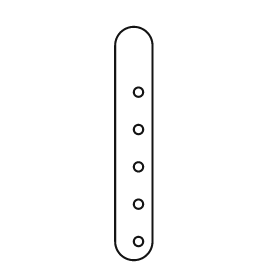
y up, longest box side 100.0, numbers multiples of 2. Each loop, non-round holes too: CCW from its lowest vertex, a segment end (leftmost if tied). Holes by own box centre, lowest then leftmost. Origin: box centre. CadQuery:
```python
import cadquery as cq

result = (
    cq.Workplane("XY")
    .moveTo(-8.0, -42.0)
    .threePointArc((0.0, -50.0), (8.0, -42.0))
    .lineTo(8.0, 42.0)
    .threePointArc((0.0, 50.0), (-8.0, 42.0))
    .close()
    .moveTo(2.0, -42.0)
    .circle(2.0)
    .moveTo(2.0, -26.0)
    .circle(2.0)
    .moveTo(2.0, -10.0)
    .circle(2.0)
    .moveTo(2.0, 6.0)
    .circle(2.0)
    .moveTo(2.0, 22.0)
    .circle(2.0)
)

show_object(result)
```